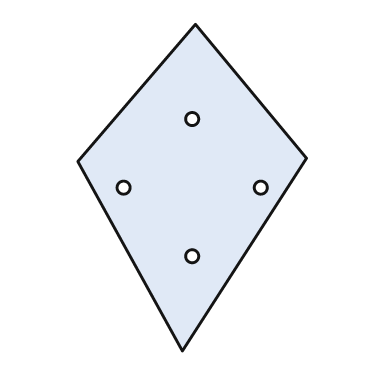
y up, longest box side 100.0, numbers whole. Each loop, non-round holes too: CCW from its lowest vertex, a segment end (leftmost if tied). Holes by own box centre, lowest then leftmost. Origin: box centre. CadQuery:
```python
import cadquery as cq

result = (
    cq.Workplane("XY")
    .moveTo(-3.0, -50.0)
    .lineTo(35.0, 9.0)
    .lineTo(1.0, 50.0)
    .lineTo(-35.0, 8.0)
    .close()
    .moveTo(0.0, -21.0)
    .circle(2.0)
    .moveTo(-21.0, 0.0)
    .circle(2.0)
    .moveTo(21.0, 0.0)
    .circle(2.0)
    .moveTo(0.0, 21.0)
    .circle(2.0)
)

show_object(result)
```